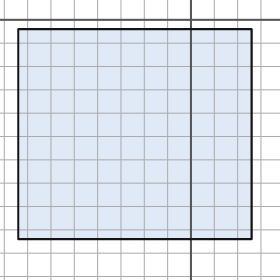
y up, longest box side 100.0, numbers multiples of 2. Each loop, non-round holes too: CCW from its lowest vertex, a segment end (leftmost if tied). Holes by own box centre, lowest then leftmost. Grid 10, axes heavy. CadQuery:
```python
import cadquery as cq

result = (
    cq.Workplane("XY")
    .moveTo(-74.0, -94.0)
    .lineTo(26.0, -94.0)
    .lineTo(26.0, -4.0)
    .lineTo(-74.0, -4.0)
    .close()
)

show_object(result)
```